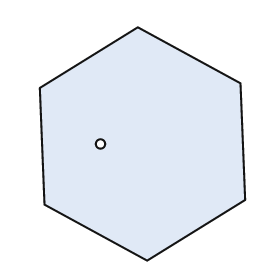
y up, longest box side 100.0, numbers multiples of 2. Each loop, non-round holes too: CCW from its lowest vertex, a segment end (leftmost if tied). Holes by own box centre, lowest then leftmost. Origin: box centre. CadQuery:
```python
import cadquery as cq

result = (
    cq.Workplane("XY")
    .moveTo(2.0, -50.0)
    .lineTo(44.0, -24.0)
    .lineTo(42.0, 26.0)
    .lineTo(-2.0, 50.0)
    .lineTo(-44.0, 24.0)
    .lineTo(-42.0, -26.0)
    .close()
    .moveTo(-18.0, 0.0)
    .circle(2.0)
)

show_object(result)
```